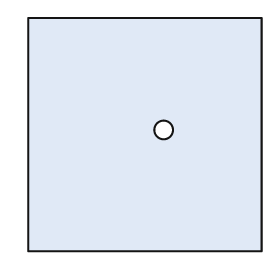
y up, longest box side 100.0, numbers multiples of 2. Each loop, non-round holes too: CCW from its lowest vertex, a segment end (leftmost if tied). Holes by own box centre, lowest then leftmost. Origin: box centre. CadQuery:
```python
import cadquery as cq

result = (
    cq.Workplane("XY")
    .moveTo(-50.0, -50.0)
    .lineTo(50.0, -50.0)
    .lineTo(50.0, 50.0)
    .lineTo(-50.0, 50.0)
    .close()
    .moveTo(8.0, 2.0)
    .circle(4.0)
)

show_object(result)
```